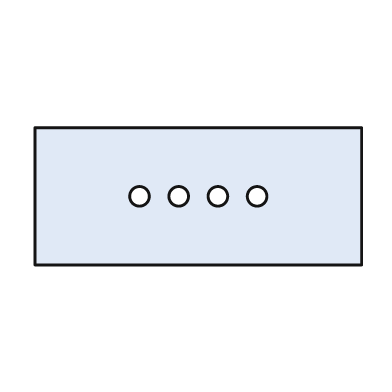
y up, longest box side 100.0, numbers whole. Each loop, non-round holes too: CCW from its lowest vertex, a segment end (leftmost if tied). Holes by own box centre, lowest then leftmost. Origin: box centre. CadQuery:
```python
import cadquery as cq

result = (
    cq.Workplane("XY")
    .moveTo(-50.0, -21.0)
    .lineTo(50.0, -21.0)
    .lineTo(50.0, 21.0)
    .lineTo(-50.0, 21.0)
    .close()
    .moveTo(-18.0, 0.0)
    .circle(3.0)
    .moveTo(-6.0, 0.0)
    .circle(3.0)
    .moveTo(6.0, 0.0)
    .circle(3.0)
    .moveTo(18.0, 0.0)
    .circle(3.0)
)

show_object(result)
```